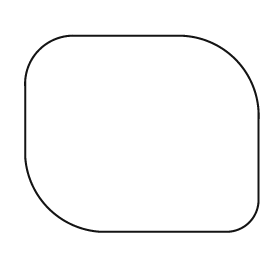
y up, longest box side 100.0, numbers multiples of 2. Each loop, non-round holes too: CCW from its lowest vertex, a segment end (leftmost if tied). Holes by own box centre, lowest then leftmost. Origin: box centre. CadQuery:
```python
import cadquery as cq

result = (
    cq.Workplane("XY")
    .moveTo(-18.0, -42.0)
    .lineTo(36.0, -42.0)
    .threePointArc((46.0, -38.0), (50.0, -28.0))
    .lineTo(50.0, 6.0)
    .threePointArc((40.0, 32.0), (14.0, 42.0))
    .lineTo(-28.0, 42.0)
    .threePointArc((-44.0, 36.0), (-50.0, 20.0))
    .lineTo(-50.0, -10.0)
    .threePointArc((-40.0, -32.0), (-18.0, -42.0))
    .close()
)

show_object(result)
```